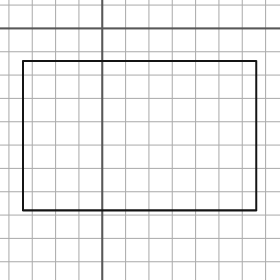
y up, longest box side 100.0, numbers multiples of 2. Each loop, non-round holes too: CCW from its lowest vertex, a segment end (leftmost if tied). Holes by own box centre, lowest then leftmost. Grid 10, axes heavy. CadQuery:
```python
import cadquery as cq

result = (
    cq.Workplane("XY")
    .moveTo(-34.0, -78.0)
    .lineTo(66.0, -78.0)
    .lineTo(66.0, -14.0)
    .lineTo(-34.0, -14.0)
    .close()
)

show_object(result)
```